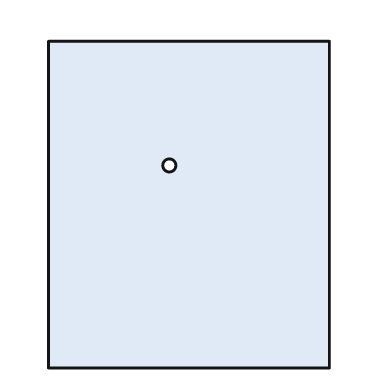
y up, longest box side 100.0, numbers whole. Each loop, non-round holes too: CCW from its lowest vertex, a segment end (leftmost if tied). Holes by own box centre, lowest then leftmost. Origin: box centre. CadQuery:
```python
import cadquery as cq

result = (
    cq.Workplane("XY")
    .moveTo(-43.0, -50.0)
    .lineTo(43.0, -50.0)
    .lineTo(43.0, 50.0)
    .lineTo(-43.0, 50.0)
    .close()
    .moveTo(-6.0, 12.0)
    .circle(2.0)
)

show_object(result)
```